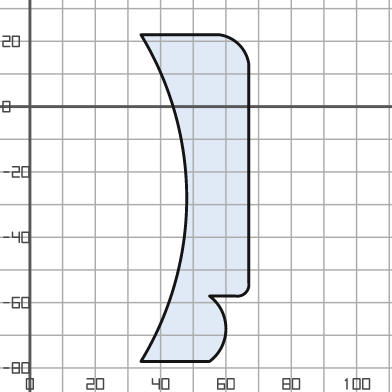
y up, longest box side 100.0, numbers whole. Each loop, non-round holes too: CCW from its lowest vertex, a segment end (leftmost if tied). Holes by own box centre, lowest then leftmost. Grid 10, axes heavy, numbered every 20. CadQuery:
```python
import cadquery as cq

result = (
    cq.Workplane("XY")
    .moveTo(34.0, -78.0)
    .lineTo(55.0, -78.0)
    .threePointArc((60.0, -68.0), (55.0, -58.0))
    .lineTo(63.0, -58.0)
    .threePointArc((66.0, -57.0), (67.0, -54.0))
    .lineTo(67.0, 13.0)
    .threePointArc((64.0, 19.0), (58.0, 22.0))
    .lineTo(34.0, 22.0)
    .threePointArc((48.0, -28.0), (34.0, -78.0))
    .close()
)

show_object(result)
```